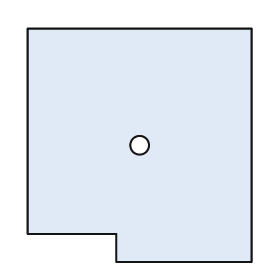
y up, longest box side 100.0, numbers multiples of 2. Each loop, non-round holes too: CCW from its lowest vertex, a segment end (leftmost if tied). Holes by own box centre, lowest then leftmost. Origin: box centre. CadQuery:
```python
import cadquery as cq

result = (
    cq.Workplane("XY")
    .moveTo(-10.0, -50.0)
    .lineTo(48.0, -50.0)
    .lineTo(48.0, 50.0)
    .lineTo(-48.0, 50.0)
    .lineTo(-48.0, -38.0)
    .lineTo(-10.0, -38.0)
    .close()
    .moveTo(0.0, 0.0)
    .circle(4.0)
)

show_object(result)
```